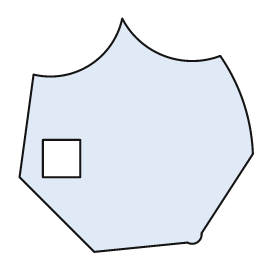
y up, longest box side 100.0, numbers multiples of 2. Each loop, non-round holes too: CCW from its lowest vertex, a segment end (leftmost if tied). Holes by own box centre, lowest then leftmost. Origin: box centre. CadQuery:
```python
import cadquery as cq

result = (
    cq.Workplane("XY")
    .moveTo(-18.0, -50.0)
    .lineTo(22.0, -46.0)
    .threePointArc((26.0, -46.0), (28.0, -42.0))
    .lineTo(50.0, -8.0)
    .threePointArc((46.0, 14.0), (36.0, 34.0))
    .threePointArc((12.0, 34.0), (-6.0, 50.0))
    .threePointArc((-20.0, 30.0), (-44.0, 26.0))
    .lineTo(-50.0, -18.0)
    .close()
    .moveTo(-40.0, -18.0)
    .lineTo(-24.0, -18.0)
    .lineTo(-24.0, -2.0)
    .lineTo(-40.0, -2.0)
    .close()
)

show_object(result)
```